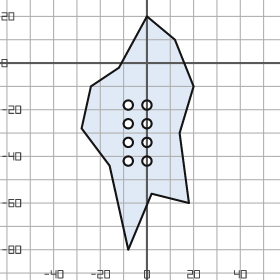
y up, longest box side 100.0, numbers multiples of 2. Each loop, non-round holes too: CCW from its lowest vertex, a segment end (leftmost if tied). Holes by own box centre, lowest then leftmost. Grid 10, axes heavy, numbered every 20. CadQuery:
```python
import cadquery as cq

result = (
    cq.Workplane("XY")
    .moveTo(-8.0, -80.0)
    .lineTo(2.0, -56.0)
    .lineTo(18.0, -60.0)
    .lineTo(14.0, -30.0)
    .lineTo(20.0, -10.0)
    .lineTo(12.0, 10.0)
    .lineTo(0.0, 20.0)
    .lineTo(-12.0, -2.0)
    .lineTo(-24.0, -10.0)
    .lineTo(-28.0, -28.0)
    .lineTo(-16.0, -44.0)
    .close()
    .moveTo(-8.0, -42.0)
    .circle(2.0)
    .moveTo(0.0, -42.0)
    .circle(2.0)
    .moveTo(-8.0, -34.0)
    .circle(2.0)
    .moveTo(0.0, -34.0)
    .circle(2.0)
    .moveTo(-8.0, -26.0)
    .circle(2.0)
    .moveTo(0.0, -26.0)
    .circle(2.0)
    .moveTo(-8.0, -18.0)
    .circle(2.0)
    .moveTo(0.0, -18.0)
    .circle(2.0)
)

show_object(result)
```